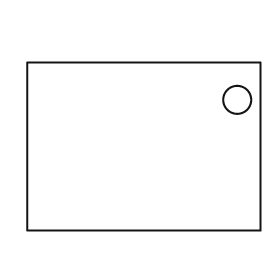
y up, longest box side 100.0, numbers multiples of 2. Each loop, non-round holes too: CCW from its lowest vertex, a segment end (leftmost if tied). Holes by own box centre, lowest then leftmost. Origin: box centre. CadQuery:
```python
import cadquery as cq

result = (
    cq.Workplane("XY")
    .moveTo(-50.0, -36.0)
    .lineTo(50.0, -36.0)
    .lineTo(50.0, 36.0)
    .lineTo(-50.0, 36.0)
    .close()
    .moveTo(40.0, 20.0)
    .circle(6.0)
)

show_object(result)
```